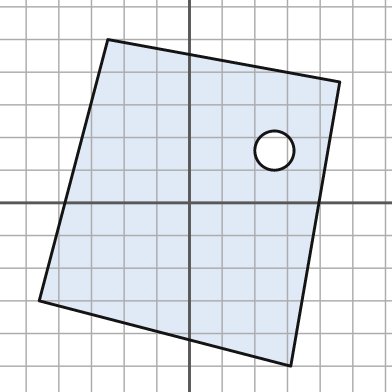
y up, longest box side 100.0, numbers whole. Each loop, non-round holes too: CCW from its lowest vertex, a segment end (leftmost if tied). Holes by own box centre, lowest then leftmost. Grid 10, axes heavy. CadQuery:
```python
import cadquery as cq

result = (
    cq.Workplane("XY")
    .moveTo(31.0, -50.0)
    .lineTo(46.0, 37.0)
    .lineTo(-25.0, 50.0)
    .lineTo(-46.0, -30.0)
    .close()
    .moveTo(26.0, 16.0)
    .circle(6.0)
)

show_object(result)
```